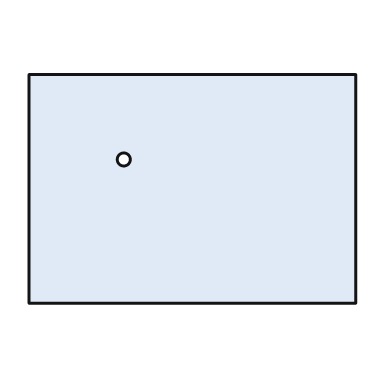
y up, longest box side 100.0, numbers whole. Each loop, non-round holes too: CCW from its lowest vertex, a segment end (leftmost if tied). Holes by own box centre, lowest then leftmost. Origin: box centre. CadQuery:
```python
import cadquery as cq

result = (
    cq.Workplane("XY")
    .moveTo(-50.0, -35.0)
    .lineTo(50.0, -35.0)
    .lineTo(50.0, 35.0)
    .lineTo(-50.0, 35.0)
    .close()
    .moveTo(-21.0, 9.0)
    .circle(2.0)
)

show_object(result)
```